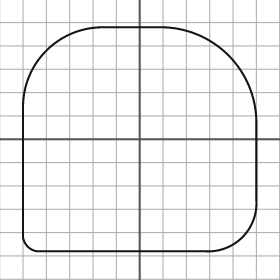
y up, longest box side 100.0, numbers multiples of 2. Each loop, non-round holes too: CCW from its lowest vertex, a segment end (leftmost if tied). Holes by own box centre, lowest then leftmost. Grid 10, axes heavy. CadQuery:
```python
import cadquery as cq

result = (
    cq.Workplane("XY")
    .moveTo(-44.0, -48.0)
    .lineTo(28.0, -48.0)
    .threePointArc((44.0, -42.0), (50.0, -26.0))
    .lineTo(50.0, 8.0)
    .threePointArc((38.0, 36.0), (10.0, 48.0))
    .lineTo(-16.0, 48.0)
    .threePointArc((-40.0, 38.0), (-50.0, 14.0))
    .lineTo(-50.0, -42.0)
    .threePointArc((-48.0, -46.0), (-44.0, -48.0))
    .close()
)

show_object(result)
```